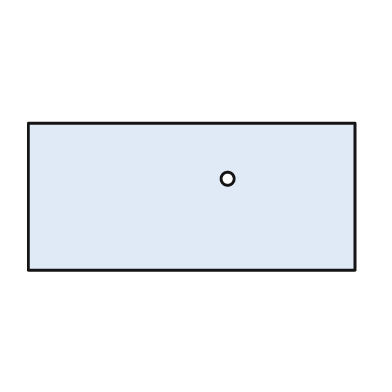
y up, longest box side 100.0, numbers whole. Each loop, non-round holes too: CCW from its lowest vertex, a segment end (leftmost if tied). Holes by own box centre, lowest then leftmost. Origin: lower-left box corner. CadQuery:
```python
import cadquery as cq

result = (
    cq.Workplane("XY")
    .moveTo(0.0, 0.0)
    .lineTo(100.0, 0.0)
    .lineTo(100.0, 45.0)
    .lineTo(0.0, 45.0)
    .close()
    .moveTo(61.0, 28.0)
    .circle(2.0)
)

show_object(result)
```